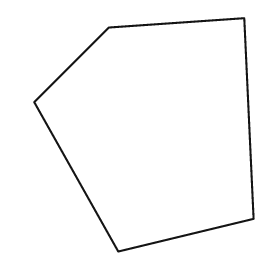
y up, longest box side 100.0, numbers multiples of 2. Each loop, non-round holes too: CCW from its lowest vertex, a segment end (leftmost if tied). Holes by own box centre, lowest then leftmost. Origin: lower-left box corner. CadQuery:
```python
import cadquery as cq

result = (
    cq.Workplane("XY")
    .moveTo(36.0, 0.0)
    .lineTo(94.0, 14.0)
    .lineTo(90.0, 100.0)
    .lineTo(32.0, 96.0)
    .lineTo(0.0, 64.0)
    .close()
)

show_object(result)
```